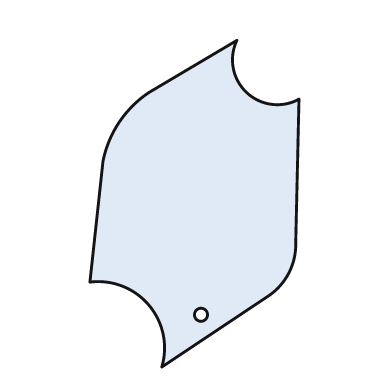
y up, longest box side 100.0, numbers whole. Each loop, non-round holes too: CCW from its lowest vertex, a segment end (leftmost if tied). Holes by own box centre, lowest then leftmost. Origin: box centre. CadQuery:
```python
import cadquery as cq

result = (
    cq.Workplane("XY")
    .moveTo(-10.0, -50.0)
    .lineTo(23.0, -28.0)
    .threePointArc((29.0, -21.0), (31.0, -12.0))
    .lineTo(32.0, 32.0)
    .threePointArc((16.0, 34.0), (13.0, 50.0))
    .lineTo(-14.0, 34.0)
    .threePointArc((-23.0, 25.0), (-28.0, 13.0))
    .lineTo(-32.0, -24.0)
    .threePointArc((-14.0, -31.0), (-10.0, -50.0))
    .close()
    .moveTo(2.0, -34.0)
    .circle(2.0)
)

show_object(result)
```